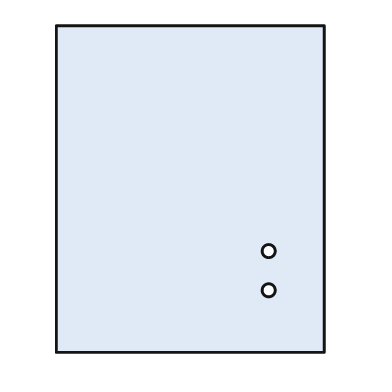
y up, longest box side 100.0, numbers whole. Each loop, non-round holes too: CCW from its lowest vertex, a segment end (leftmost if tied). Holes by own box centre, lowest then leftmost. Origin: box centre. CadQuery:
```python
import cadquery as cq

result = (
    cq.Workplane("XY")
    .moveTo(-41.0, -50.0)
    .lineTo(41.0, -50.0)
    .lineTo(41.0, 50.0)
    .lineTo(-41.0, 50.0)
    .close()
    .moveTo(24.0, -31.0)
    .circle(2.0)
    .moveTo(24.0, -19.0)
    .circle(2.0)
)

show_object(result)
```